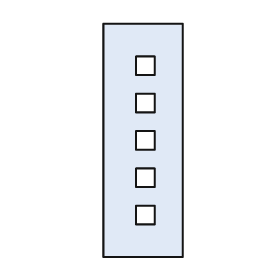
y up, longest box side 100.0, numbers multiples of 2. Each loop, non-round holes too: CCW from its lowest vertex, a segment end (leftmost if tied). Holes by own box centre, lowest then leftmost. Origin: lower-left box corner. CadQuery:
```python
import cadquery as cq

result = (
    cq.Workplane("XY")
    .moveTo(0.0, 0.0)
    .lineTo(34.0, 0.0)
    .lineTo(34.0, 100.0)
    .lineTo(0.0, 100.0)
    .close()
    .moveTo(14.0, 14.0)
    .lineTo(22.0, 14.0)
    .lineTo(22.0, 22.0)
    .lineTo(14.0, 22.0)
    .close()
    .moveTo(14.0, 30.0)
    .lineTo(22.0, 30.0)
    .lineTo(22.0, 38.0)
    .lineTo(14.0, 38.0)
    .close()
    .moveTo(14.0, 46.0)
    .lineTo(22.0, 46.0)
    .lineTo(22.0, 54.0)
    .lineTo(14.0, 54.0)
    .close()
    .moveTo(14.0, 62.0)
    .lineTo(22.0, 62.0)
    .lineTo(22.0, 70.0)
    .lineTo(14.0, 70.0)
    .close()
    .moveTo(14.0, 78.0)
    .lineTo(22.0, 78.0)
    .lineTo(22.0, 86.0)
    .lineTo(14.0, 86.0)
    .close()
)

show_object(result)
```